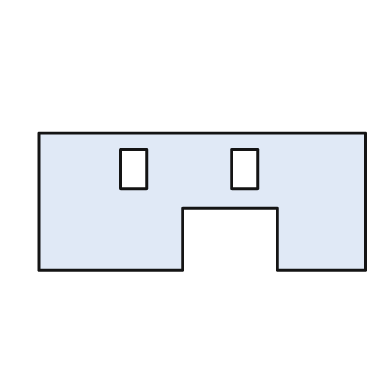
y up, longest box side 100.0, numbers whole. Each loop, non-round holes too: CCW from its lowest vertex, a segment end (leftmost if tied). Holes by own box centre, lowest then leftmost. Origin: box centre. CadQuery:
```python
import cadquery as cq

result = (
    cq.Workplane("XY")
    .moveTo(-50.0, -21.0)
    .lineTo(-6.0, -21.0)
    .lineTo(-6.0, -2.0)
    .lineTo(23.0, -2.0)
    .lineTo(23.0, -21.0)
    .lineTo(50.0, -21.0)
    .lineTo(50.0, 21.0)
    .lineTo(-50.0, 21.0)
    .close()
    .moveTo(-25.0, 4.0)
    .lineTo(-17.0, 4.0)
    .lineTo(-17.0, 16.0)
    .lineTo(-25.0, 16.0)
    .close()
    .moveTo(9.0, 4.0)
    .lineTo(17.0, 4.0)
    .lineTo(17.0, 16.0)
    .lineTo(9.0, 16.0)
    .close()
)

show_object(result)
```